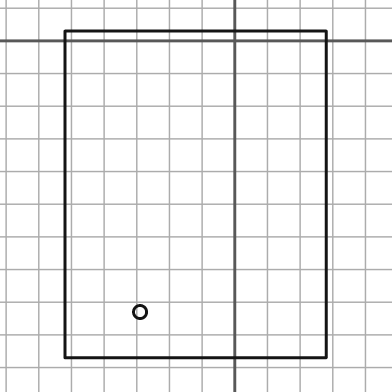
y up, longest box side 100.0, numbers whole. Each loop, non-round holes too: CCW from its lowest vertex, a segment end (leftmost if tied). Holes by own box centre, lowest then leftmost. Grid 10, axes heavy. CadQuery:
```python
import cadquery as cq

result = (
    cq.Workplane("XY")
    .moveTo(-52.0, -97.0)
    .lineTo(28.0, -97.0)
    .lineTo(28.0, 3.0)
    .lineTo(-52.0, 3.0)
    .close()
    .moveTo(-29.0, -83.0)
    .circle(2.0)
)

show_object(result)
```